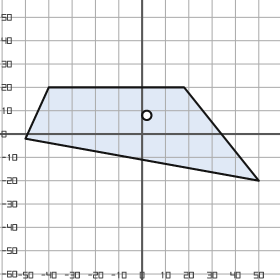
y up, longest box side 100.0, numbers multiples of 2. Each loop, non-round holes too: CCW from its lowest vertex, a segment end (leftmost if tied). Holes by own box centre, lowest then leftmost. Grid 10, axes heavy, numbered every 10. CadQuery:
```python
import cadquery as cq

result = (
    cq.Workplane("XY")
    .moveTo(50.0, -20.0)
    .lineTo(18.0, 20.0)
    .lineTo(-40.0, 20.0)
    .lineTo(-50.0, -2.0)
    .close()
    .moveTo(2.0, 8.0)
    .circle(2.0)
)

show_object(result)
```